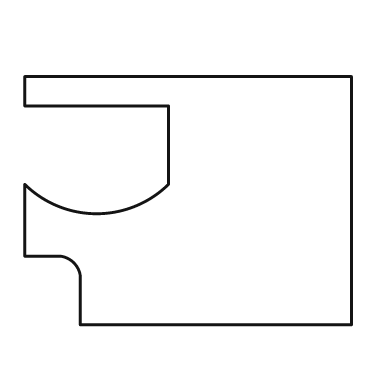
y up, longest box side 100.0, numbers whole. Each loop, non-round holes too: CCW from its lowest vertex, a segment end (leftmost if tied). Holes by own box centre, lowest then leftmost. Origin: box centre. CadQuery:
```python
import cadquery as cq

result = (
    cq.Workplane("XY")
    .moveTo(-33.0, -38.0)
    .lineTo(50.0, -38.0)
    .lineTo(50.0, 38.0)
    .lineTo(-50.0, 38.0)
    .lineTo(-50.0, 29.0)
    .lineTo(-6.0, 29.0)
    .lineTo(-6.0, 5.0)
    .threePointArc((-28.0, -4.0), (-50.0, 5.0))
    .lineTo(-50.0, -17.0)
    .lineTo(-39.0, -17.0)
    .threePointArc((-35.0, -19.0), (-33.0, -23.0))
    .close()
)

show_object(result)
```